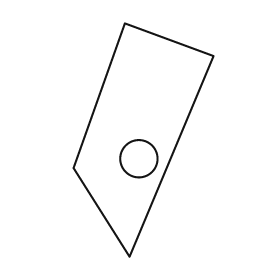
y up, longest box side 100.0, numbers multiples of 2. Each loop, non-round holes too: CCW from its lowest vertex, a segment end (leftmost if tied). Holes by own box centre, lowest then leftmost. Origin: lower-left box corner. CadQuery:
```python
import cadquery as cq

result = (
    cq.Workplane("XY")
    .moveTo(24.0, 0.0)
    .lineTo(60.0, 86.0)
    .lineTo(22.0, 100.0)
    .lineTo(0.0, 38.0)
    .close()
    .moveTo(28.0, 42.0)
    .circle(8.0)
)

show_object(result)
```